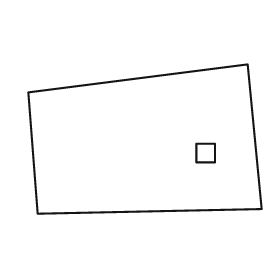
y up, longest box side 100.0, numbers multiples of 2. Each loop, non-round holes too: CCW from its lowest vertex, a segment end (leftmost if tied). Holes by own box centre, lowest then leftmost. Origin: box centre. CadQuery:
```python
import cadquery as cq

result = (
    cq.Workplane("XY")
    .moveTo(-46.0, -32.0)
    .lineTo(50.0, -30.0)
    .lineTo(44.0, 32.0)
    .lineTo(-50.0, 20.0)
    .close()
    .moveTo(22.0, -10.0)
    .lineTo(30.0, -10.0)
    .lineTo(30.0, -2.0)
    .lineTo(22.0, -2.0)
    .close()
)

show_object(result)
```